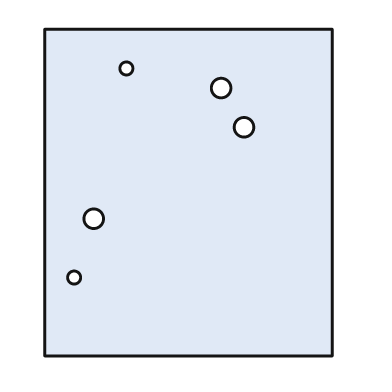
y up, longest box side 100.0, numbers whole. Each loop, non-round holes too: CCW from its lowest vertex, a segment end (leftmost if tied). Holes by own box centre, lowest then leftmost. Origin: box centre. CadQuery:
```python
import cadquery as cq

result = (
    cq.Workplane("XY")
    .moveTo(-44.0, -50.0)
    .lineTo(44.0, -50.0)
    .lineTo(44.0, 50.0)
    .lineTo(-44.0, 50.0)
    .close()
    .moveTo(-35.0, -26.0)
    .circle(2.0)
    .moveTo(-29.0, -8.0)
    .circle(3.0)
    .moveTo(17.0, 20.0)
    .circle(3.0)
    .moveTo(10.0, 32.0)
    .circle(3.0)
    .moveTo(-19.0, 38.0)
    .circle(2.0)
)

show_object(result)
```